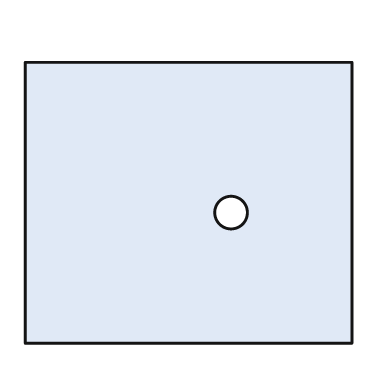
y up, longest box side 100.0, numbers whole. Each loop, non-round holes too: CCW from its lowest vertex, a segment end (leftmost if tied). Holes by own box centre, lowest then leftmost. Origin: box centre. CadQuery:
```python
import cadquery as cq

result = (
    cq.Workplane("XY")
    .moveTo(-50.0, -43.0)
    .lineTo(50.0, -43.0)
    .lineTo(50.0, 43.0)
    .lineTo(-50.0, 43.0)
    .close()
    .moveTo(13.0, -3.0)
    .circle(5.0)
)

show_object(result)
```